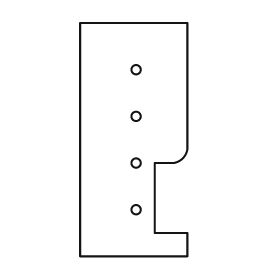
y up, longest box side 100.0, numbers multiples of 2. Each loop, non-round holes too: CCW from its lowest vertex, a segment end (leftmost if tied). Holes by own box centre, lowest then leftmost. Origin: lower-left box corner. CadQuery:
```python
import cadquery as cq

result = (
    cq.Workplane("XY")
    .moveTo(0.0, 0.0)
    .lineTo(46.0, 0.0)
    .lineTo(46.0, 10.0)
    .lineTo(32.0, 10.0)
    .lineTo(32.0, 40.0)
    .lineTo(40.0, 40.0)
    .threePointArc((44.0, 42.0), (46.0, 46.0))
    .lineTo(46.0, 100.0)
    .lineTo(0.0, 100.0)
    .close()
    .moveTo(24.0, 20.0)
    .circle(2.0)
    .moveTo(24.0, 40.0)
    .circle(2.0)
    .moveTo(24.0, 60.0)
    .circle(2.0)
    .moveTo(24.0, 80.0)
    .circle(2.0)
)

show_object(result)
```